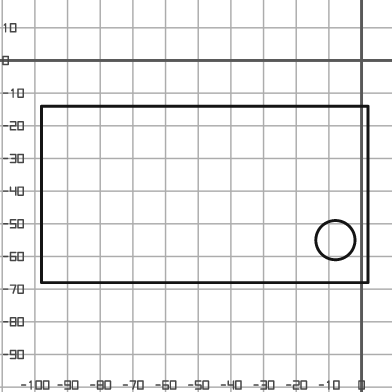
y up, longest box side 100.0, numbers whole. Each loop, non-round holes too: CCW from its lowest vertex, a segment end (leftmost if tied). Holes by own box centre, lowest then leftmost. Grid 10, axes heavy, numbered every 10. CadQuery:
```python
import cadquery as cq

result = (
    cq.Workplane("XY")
    .moveTo(-98.0, -68.0)
    .lineTo(2.0, -68.0)
    .lineTo(2.0, -14.0)
    .lineTo(-98.0, -14.0)
    .close()
    .moveTo(-8.0, -55.0)
    .circle(6.0)
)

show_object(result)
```